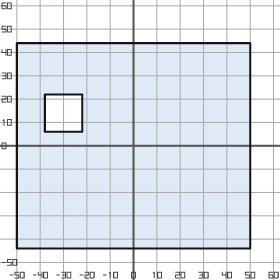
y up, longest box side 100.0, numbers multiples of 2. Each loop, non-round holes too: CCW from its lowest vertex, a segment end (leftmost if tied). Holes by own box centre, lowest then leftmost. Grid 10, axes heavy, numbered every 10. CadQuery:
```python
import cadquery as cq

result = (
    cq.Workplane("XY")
    .moveTo(-50.0, -44.0)
    .lineTo(50.0, -44.0)
    .lineTo(50.0, 44.0)
    .lineTo(-50.0, 44.0)
    .close()
    .moveTo(-38.0, 6.0)
    .lineTo(-22.0, 6.0)
    .lineTo(-22.0, 22.0)
    .lineTo(-38.0, 22.0)
    .close()
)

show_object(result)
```